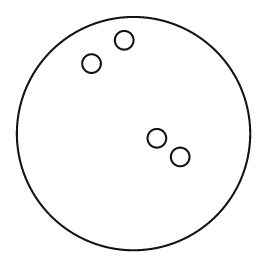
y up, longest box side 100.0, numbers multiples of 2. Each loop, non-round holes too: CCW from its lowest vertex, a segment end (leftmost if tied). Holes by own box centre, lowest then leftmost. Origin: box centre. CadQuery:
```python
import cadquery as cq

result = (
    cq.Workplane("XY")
    .moveTo(0.0, 0.0)
    .circle(50.0)
    .moveTo(20.0, -10.0)
    .circle(4.0)
    .moveTo(10.0, -2.0)
    .circle(4.0)
    .moveTo(-18.0, 30.0)
    .circle(4.0)
    .moveTo(-4.0, 40.0)
    .circle(4.0)
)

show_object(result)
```